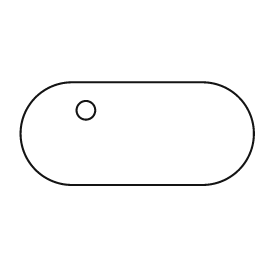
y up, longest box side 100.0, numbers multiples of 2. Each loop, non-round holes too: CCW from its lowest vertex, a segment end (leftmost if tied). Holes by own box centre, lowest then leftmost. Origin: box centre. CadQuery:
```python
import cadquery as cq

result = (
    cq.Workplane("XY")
    .moveTo(-28.0, -22.0)
    .lineTo(28.0, -22.0)
    .threePointArc((50.0, 0.0), (28.0, 22.0))
    .lineTo(-28.0, 22.0)
    .threePointArc((-50.0, 0.0), (-28.0, -22.0))
    .close()
    .moveTo(-22.0, 10.0)
    .circle(4.0)
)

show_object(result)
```